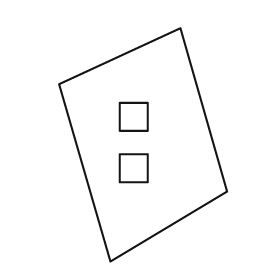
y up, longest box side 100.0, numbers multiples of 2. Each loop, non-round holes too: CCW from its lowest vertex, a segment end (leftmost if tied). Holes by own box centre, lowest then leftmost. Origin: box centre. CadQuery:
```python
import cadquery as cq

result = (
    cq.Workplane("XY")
    .moveTo(-14.0, -50.0)
    .lineTo(36.0, -20.0)
    .lineTo(16.0, 50.0)
    .lineTo(-36.0, 26.0)
    .close()
    .moveTo(-10.0, -16.0)
    .lineTo(2.0, -16.0)
    .lineTo(2.0, -4.0)
    .lineTo(-10.0, -4.0)
    .close()
    .moveTo(-10.0, 6.0)
    .lineTo(2.0, 6.0)
    .lineTo(2.0, 18.0)
    .lineTo(-10.0, 18.0)
    .close()
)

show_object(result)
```